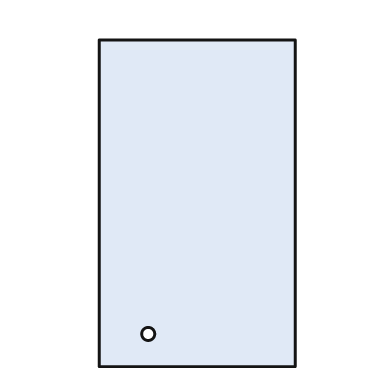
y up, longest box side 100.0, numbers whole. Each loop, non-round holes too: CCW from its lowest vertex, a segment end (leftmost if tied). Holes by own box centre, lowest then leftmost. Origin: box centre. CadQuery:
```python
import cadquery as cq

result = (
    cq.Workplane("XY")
    .moveTo(-30.0, -50.0)
    .lineTo(30.0, -50.0)
    .lineTo(30.0, 50.0)
    .lineTo(-30.0, 50.0)
    .close()
    .moveTo(-15.0, -40.0)
    .circle(2.0)
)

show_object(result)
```